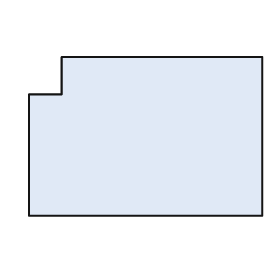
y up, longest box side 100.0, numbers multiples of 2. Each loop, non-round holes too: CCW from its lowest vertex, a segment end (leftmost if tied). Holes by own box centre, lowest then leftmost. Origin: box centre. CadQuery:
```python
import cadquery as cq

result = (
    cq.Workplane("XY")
    .moveTo(-50.0, -34.0)
    .lineTo(50.0, -34.0)
    .lineTo(50.0, 34.0)
    .lineTo(-36.0, 34.0)
    .lineTo(-36.0, 18.0)
    .lineTo(-50.0, 18.0)
    .close()
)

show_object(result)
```